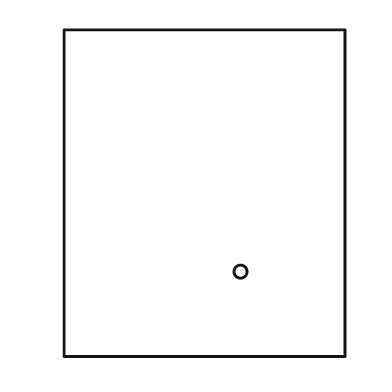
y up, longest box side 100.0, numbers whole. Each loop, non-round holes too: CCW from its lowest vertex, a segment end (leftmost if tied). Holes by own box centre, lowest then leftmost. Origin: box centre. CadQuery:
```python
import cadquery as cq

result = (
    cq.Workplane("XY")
    .moveTo(-43.0, -50.0)
    .lineTo(43.0, -50.0)
    .lineTo(43.0, 50.0)
    .lineTo(-43.0, 50.0)
    .close()
    .moveTo(11.0, -24.0)
    .circle(2.0)
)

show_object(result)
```